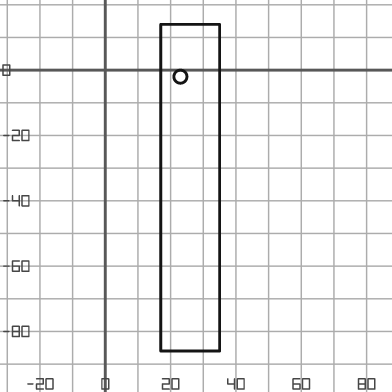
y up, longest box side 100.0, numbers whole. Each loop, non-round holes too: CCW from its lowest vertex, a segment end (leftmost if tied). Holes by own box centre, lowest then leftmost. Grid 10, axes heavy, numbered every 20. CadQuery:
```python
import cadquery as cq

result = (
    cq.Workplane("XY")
    .moveTo(17.0, -86.0)
    .lineTo(35.0, -86.0)
    .lineTo(35.0, 14.0)
    .lineTo(17.0, 14.0)
    .close()
    .moveTo(23.0, -2.0)
    .circle(2.0)
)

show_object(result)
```